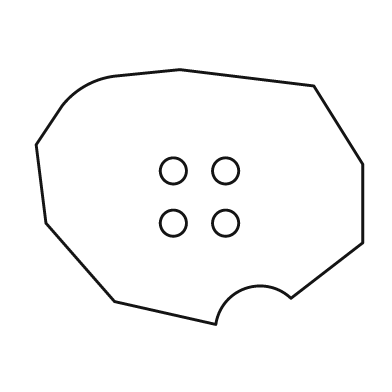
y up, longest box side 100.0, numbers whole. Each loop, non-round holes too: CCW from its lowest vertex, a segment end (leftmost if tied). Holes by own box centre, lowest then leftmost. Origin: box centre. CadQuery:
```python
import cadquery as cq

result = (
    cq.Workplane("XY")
    .moveTo(5.0, -39.0)
    .threePointArc((14.0, -28.0), (28.0, -31.0))
    .lineTo(50.0, -14.0)
    .lineTo(50.0, 10.0)
    .lineTo(35.0, 34.0)
    .lineTo(-6.0, 39.0)
    .lineTo(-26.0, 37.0)
    .threePointArc((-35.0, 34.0), (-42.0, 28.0))
    .lineTo(-50.0, 16.0)
    .lineTo(-47.0, -8.0)
    .lineTo(-26.0, -32.0)
    .close()
    .moveTo(-8.0, -8.0)
    .circle(4.0)
    .moveTo(8.0, -8.0)
    .circle(4.0)
    .moveTo(-8.0, 8.0)
    .circle(4.0)
    .moveTo(8.0, 8.0)
    .circle(4.0)
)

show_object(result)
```